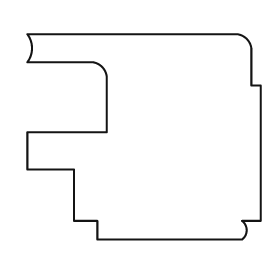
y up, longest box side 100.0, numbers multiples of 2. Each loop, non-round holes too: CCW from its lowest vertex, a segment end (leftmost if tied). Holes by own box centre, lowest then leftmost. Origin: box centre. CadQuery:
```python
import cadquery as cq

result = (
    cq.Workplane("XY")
    .moveTo(-20.0, -44.0)
    .lineTo(42.0, -44.0)
    .threePointArc((44.0, -40.0), (42.0, -36.0))
    .lineTo(50.0, -36.0)
    .lineTo(50.0, 22.0)
    .lineTo(46.0, 22.0)
    .lineTo(46.0, 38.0)
    .threePointArc((44.0, 42.0), (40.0, 44.0))
    .lineTo(-50.0, 44.0)
    .threePointArc((-48.0, 38.0), (-50.0, 32.0))
    .lineTo(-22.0, 32.0)
    .threePointArc((-18.0, 30.0), (-16.0, 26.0))
    .lineTo(-16.0, 2.0)
    .lineTo(-50.0, 2.0)
    .lineTo(-50.0, -14.0)
    .lineTo(-30.0, -14.0)
    .lineTo(-30.0, -36.0)
    .lineTo(-20.0, -36.0)
    .close()
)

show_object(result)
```